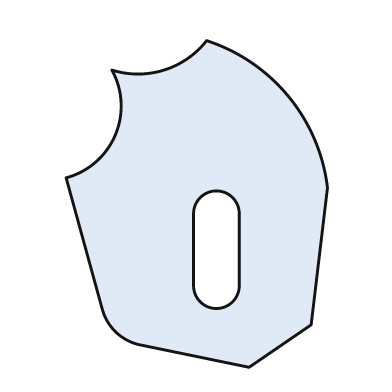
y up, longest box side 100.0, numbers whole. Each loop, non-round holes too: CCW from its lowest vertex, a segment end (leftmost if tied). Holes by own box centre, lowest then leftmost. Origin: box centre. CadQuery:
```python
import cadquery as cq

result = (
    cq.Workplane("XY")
    .moveTo(16.0, -50.0)
    .lineTo(35.0, -37.0)
    .lineTo(40.0, 5.0)
    .threePointArc((28.0, 33.0), (3.0, 50.0))
    .threePointArc((-10.0, 41.0), (-26.0, 41.0))
    .threePointArc((-25.0, 21.0), (-40.0, 8.0))
    .lineTo(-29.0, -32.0)
    .threePointArc((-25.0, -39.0), (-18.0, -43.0))
    .close()
    .moveTo(-1.0, -25.0)
    .threePointArc((6.0, -32.0), (13.0, -25.0))
    .lineTo(13.0, -3.0)
    .threePointArc((6.0, 4.0), (-1.0, -3.0))
    .close()
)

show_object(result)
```